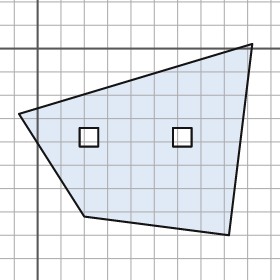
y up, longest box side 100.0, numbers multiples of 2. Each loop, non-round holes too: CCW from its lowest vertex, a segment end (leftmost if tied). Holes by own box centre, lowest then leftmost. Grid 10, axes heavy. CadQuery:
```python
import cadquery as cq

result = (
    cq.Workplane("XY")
    .moveTo(82.0, -80.0)
    .lineTo(92.0, 2.0)
    .lineTo(-8.0, -28.0)
    .lineTo(20.0, -72.0)
    .close()
    .moveTo(18.0, -42.0)
    .lineTo(26.0, -42.0)
    .lineTo(26.0, -34.0)
    .lineTo(18.0, -34.0)
    .close()
    .moveTo(58.0, -42.0)
    .lineTo(66.0, -42.0)
    .lineTo(66.0, -34.0)
    .lineTo(58.0, -34.0)
    .close()
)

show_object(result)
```